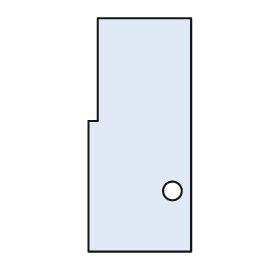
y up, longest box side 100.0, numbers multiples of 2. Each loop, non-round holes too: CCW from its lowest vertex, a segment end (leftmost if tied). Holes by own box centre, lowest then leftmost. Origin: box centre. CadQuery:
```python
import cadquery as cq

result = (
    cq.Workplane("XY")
    .moveTo(-22.0, -50.0)
    .lineTo(22.0, -50.0)
    .lineTo(22.0, 50.0)
    .lineTo(-18.0, 50.0)
    .lineTo(-18.0, 6.0)
    .lineTo(-22.0, 6.0)
    .close()
    .moveTo(14.0, -24.0)
    .circle(4.0)
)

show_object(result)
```